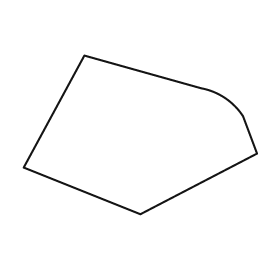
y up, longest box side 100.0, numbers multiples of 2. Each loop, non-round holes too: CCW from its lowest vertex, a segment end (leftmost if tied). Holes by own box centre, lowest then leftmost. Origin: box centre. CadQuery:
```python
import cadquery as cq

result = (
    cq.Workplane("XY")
    .moveTo(0.0, -34.0)
    .lineTo(50.0, -8.0)
    .lineTo(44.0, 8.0)
    .threePointArc((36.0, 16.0), (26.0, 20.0))
    .lineTo(-24.0, 34.0)
    .lineTo(-50.0, -14.0)
    .close()
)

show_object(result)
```